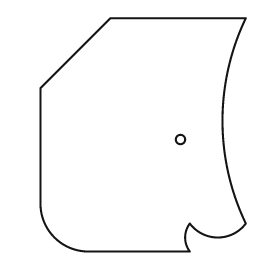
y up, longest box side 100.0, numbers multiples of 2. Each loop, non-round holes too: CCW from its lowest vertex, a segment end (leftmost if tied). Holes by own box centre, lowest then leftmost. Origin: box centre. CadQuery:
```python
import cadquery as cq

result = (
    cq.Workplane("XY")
    .moveTo(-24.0, -50.0)
    .lineTo(20.0, -50.0)
    .threePointArc((18.0, -44.0), (20.0, -38.0))
    .threePointArc((32.0, -44.0), (44.0, -38.0))
    .threePointArc((34.0, 6.0), (44.0, 50.0))
    .lineTo(-14.0, 50.0)
    .lineTo(-44.0, 20.0)
    .lineTo(-44.0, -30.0)
    .threePointArc((-38.0, -44.0), (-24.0, -50.0))
    .close()
    .moveTo(16.0, -2.0)
    .circle(2.0)
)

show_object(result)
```